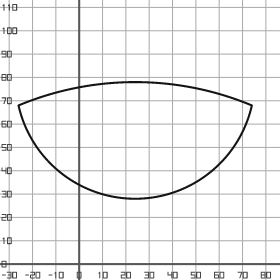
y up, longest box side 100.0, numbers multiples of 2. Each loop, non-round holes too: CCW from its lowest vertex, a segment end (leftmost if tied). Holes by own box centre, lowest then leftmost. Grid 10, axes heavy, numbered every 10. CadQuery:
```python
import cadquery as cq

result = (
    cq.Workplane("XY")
    .moveTo(-26.0, 68.0)
    .threePointArc((24.0, 28.0), (74.0, 68.0))
    .threePointArc((24.0, 78.0), (-26.0, 68.0))
    .close()
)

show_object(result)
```